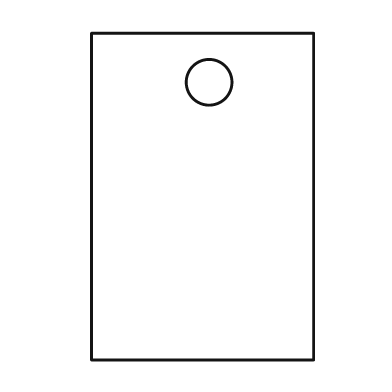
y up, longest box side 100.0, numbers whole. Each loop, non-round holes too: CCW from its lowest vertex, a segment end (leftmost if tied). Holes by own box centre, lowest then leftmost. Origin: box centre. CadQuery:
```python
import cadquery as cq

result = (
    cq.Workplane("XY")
    .moveTo(-34.0, -50.0)
    .lineTo(34.0, -50.0)
    .lineTo(34.0, 50.0)
    .lineTo(-34.0, 50.0)
    .close()
    .moveTo(2.0, 35.0)
    .circle(7.0)
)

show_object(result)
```